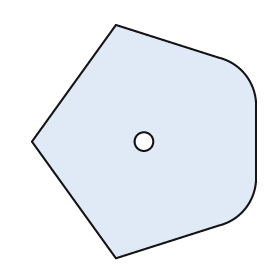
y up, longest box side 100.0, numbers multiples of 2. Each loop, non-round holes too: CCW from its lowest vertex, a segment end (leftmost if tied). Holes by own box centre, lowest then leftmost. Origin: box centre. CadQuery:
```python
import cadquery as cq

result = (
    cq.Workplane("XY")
    .moveTo(-12.0, -50.0)
    .lineTo(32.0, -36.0)
    .threePointArc((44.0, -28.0), (48.0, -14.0))
    .lineTo(48.0, 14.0)
    .threePointArc((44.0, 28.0), (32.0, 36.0))
    .lineTo(-12.0, 50.0)
    .lineTo(-48.0, 0.0)
    .close()
    .moveTo(0.0, 0.0)
    .circle(4.0)
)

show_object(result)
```